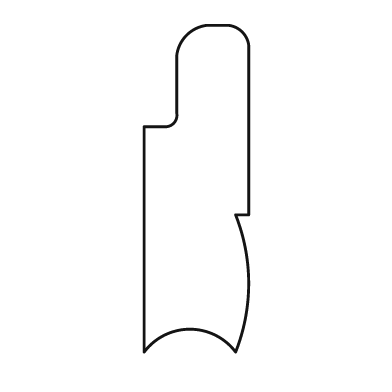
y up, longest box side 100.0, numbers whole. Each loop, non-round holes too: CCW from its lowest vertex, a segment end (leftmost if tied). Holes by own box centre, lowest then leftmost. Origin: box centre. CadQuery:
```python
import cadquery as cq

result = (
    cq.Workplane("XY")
    .moveTo(-16.0, -50.0)
    .threePointArc((-2.0, -43.0), (12.0, -50.0))
    .threePointArc((16.0, -29.0), (12.0, -8.0))
    .lineTo(16.0, -8.0)
    .lineTo(16.0, 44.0)
    .threePointArc((14.0, 48.0), (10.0, 50.0))
    .lineTo(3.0, 50.0)
    .threePointArc((-3.0, 47.0), (-6.0, 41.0))
    .lineTo(-6.0, 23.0)
    .threePointArc((-7.0, 20.0), (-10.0, 19.0))
    .lineTo(-16.0, 19.0)
    .close()
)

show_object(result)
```